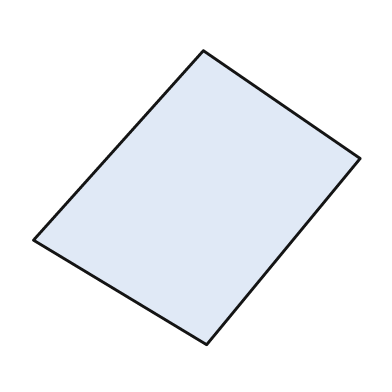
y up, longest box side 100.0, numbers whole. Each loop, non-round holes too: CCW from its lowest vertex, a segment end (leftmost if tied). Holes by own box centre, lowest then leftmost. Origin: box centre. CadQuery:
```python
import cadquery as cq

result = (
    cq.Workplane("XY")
    .moveTo(3.0, -45.0)
    .lineTo(50.0, 12.0)
    .lineTo(2.0, 45.0)
    .lineTo(-50.0, -13.0)
    .close()
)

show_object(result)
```